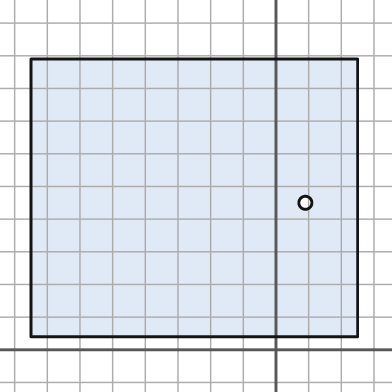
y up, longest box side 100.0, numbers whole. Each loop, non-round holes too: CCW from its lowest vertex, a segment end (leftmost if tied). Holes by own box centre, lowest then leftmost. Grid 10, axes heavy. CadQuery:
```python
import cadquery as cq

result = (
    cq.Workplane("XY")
    .moveTo(-75.0, 4.0)
    .lineTo(25.0, 4.0)
    .lineTo(25.0, 89.0)
    .lineTo(-75.0, 89.0)
    .close()
    .moveTo(9.0, 45.0)
    .circle(2.0)
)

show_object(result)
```